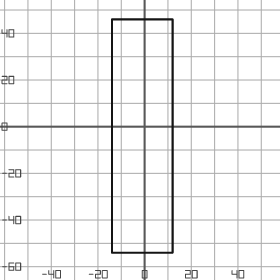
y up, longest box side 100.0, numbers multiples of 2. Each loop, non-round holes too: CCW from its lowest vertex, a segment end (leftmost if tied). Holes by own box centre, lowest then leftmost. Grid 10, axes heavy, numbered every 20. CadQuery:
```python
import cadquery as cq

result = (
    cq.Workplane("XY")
    .moveTo(-14.0, -54.0)
    .lineTo(12.0, -54.0)
    .lineTo(12.0, 46.0)
    .lineTo(-14.0, 46.0)
    .close()
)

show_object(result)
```